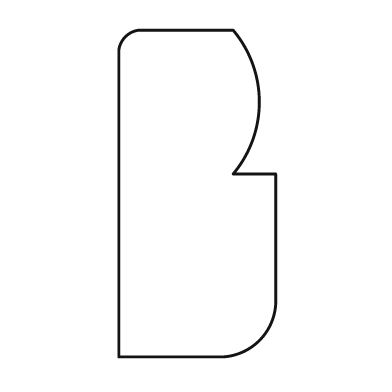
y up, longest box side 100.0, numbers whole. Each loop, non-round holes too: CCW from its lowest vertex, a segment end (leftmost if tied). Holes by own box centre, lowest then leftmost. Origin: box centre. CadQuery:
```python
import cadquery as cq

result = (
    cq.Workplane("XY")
    .moveTo(-24.0, -50.0)
    .lineTo(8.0, -50.0)
    .threePointArc((19.0, -45.0), (24.0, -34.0))
    .lineTo(24.0, 6.0)
    .lineTo(11.0, 6.0)
    .threePointArc((19.0, 28.0), (11.0, 50.0))
    .lineTo(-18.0, 50.0)
    .threePointArc((-22.0, 48.0), (-24.0, 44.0))
    .close()
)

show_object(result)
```